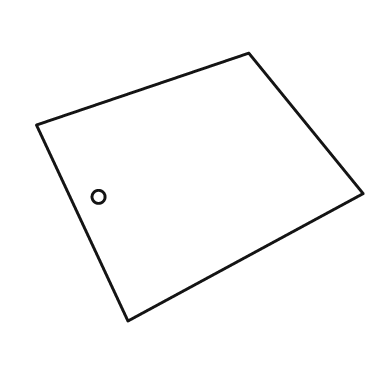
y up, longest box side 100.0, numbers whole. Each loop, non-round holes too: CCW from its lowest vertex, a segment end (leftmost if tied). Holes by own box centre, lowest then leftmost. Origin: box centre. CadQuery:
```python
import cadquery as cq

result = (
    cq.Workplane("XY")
    .moveTo(-22.0, -41.0)
    .lineTo(50.0, -2.0)
    .lineTo(15.0, 41.0)
    .lineTo(-50.0, 19.0)
    .close()
    .moveTo(-31.0, -3.0)
    .circle(2.0)
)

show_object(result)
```